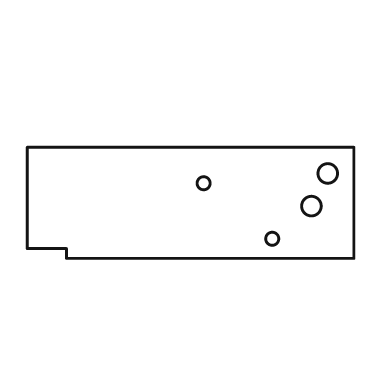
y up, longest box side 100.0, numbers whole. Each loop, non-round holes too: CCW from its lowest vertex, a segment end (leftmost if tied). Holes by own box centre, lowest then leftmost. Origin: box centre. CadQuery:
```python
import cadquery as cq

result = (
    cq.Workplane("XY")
    .moveTo(-38.0, -17.0)
    .lineTo(50.0, -17.0)
    .lineTo(50.0, 17.0)
    .lineTo(-50.0, 17.0)
    .lineTo(-50.0, -14.0)
    .lineTo(-38.0, -14.0)
    .close()
    .moveTo(25.0, -11.0)
    .circle(2.0)
    .moveTo(37.0, -1.0)
    .circle(3.0)
    .moveTo(4.0, 6.0)
    .circle(2.0)
    .moveTo(42.0, 9.0)
    .circle(3.0)
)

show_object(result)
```